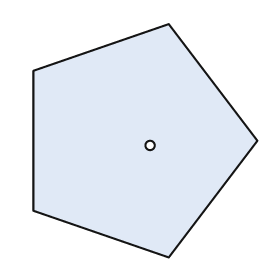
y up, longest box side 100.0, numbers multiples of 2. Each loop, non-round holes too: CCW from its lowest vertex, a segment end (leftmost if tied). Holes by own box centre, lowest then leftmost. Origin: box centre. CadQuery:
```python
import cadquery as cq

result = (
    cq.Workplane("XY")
    .moveTo(10.0, -50.0)
    .lineTo(48.0, 0.0)
    .lineTo(10.0, 50.0)
    .lineTo(-48.0, 30.0)
    .lineTo(-48.0, -30.0)
    .close()
    .moveTo(2.0, -2.0)
    .circle(2.0)
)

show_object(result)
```